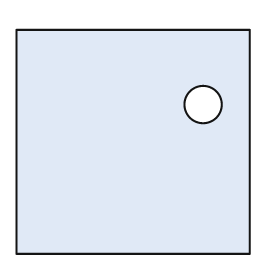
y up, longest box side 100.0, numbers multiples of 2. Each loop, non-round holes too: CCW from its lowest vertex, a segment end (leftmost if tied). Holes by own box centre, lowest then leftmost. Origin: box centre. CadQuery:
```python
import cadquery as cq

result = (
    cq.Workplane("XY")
    .moveTo(-50.0, -48.0)
    .lineTo(50.0, -48.0)
    .lineTo(50.0, 48.0)
    .lineTo(-50.0, 48.0)
    .close()
    .moveTo(30.0, 16.0)
    .circle(8.0)
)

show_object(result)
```